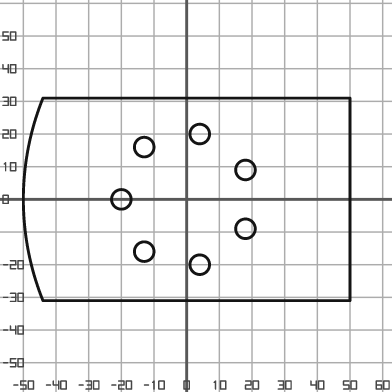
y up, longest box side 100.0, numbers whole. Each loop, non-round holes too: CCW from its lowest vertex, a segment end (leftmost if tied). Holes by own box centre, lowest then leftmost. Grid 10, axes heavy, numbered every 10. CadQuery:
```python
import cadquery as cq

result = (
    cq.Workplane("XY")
    .moveTo(-44.0, -31.0)
    .lineTo(50.0, -31.0)
    .lineTo(50.0, 31.0)
    .lineTo(-44.0, 31.0)
    .threePointArc((-50.0, 0.0), (-44.0, -31.0))
    .close()
    .moveTo(4.0, -20.0)
    .circle(3.0)
    .moveTo(-13.0, -16.0)
    .circle(3.0)
    .moveTo(18.0, -9.0)
    .circle(3.0)
    .moveTo(-20.0, 0.0)
    .circle(3.0)
    .moveTo(18.0, 9.0)
    .circle(3.0)
    .moveTo(-13.0, 16.0)
    .circle(3.0)
    .moveTo(4.0, 20.0)
    .circle(3.0)
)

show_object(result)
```